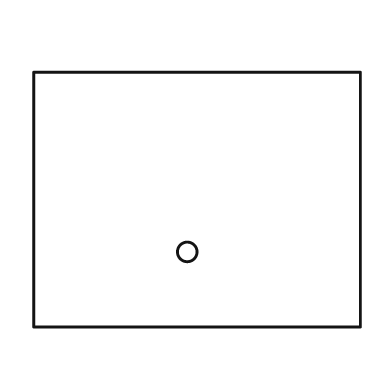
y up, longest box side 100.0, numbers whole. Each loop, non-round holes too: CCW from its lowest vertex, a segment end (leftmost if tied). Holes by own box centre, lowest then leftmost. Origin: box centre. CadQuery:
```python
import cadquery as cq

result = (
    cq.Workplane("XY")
    .moveTo(-50.0, -39.0)
    .lineTo(50.0, -39.0)
    .lineTo(50.0, 39.0)
    .lineTo(-50.0, 39.0)
    .close()
    .moveTo(-3.0, -16.0)
    .circle(3.0)
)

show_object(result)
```